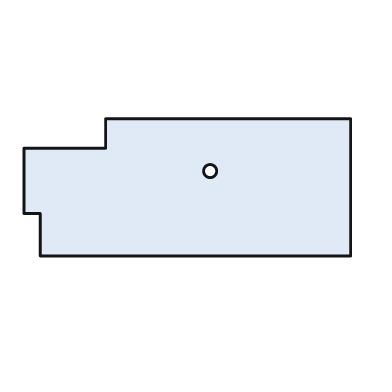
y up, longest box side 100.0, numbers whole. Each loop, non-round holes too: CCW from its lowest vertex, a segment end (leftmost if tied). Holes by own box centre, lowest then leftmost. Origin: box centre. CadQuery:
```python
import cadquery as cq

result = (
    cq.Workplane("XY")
    .moveTo(-45.0, -21.0)
    .lineTo(50.0, -21.0)
    .lineTo(50.0, 21.0)
    .lineTo(-25.0, 21.0)
    .lineTo(-25.0, 12.0)
    .lineTo(-50.0, 12.0)
    .lineTo(-50.0, -8.0)
    .lineTo(-45.0, -8.0)
    .close()
    .moveTo(7.0, 5.0)
    .circle(2.0)
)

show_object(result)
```